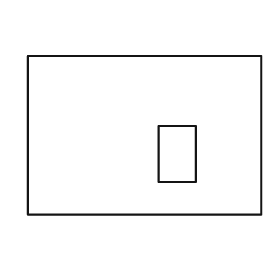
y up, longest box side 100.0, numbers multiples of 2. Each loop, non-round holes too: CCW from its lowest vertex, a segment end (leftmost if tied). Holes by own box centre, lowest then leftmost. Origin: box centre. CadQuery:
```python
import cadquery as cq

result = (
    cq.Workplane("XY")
    .moveTo(-50.0, -34.0)
    .lineTo(50.0, -34.0)
    .lineTo(50.0, 34.0)
    .lineTo(-50.0, 34.0)
    .close()
    .moveTo(6.0, -20.0)
    .lineTo(22.0, -20.0)
    .lineTo(22.0, 4.0)
    .lineTo(6.0, 4.0)
    .close()
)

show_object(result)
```